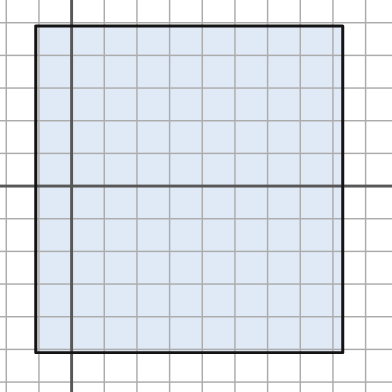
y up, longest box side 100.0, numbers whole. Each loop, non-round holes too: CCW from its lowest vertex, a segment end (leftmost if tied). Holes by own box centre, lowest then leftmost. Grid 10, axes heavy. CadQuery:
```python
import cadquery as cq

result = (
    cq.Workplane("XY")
    .moveTo(-11.0, -51.0)
    .lineTo(83.0, -51.0)
    .lineTo(83.0, 49.0)
    .lineTo(-11.0, 49.0)
    .close()
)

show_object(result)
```